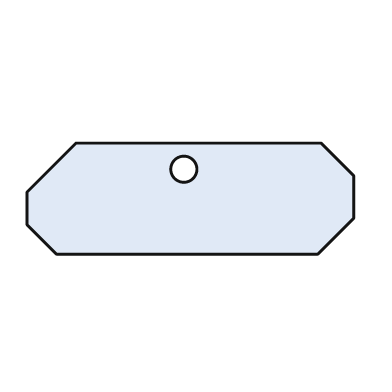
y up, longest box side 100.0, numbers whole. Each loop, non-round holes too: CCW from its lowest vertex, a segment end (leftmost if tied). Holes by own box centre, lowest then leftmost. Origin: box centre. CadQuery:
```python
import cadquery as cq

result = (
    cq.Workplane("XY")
    .moveTo(-41.0, -17.0)
    .lineTo(39.0, -17.0)
    .lineTo(50.0, -6.0)
    .lineTo(50.0, 7.0)
    .lineTo(40.0, 17.0)
    .lineTo(-35.0, 17.0)
    .lineTo(-50.0, 2.0)
    .lineTo(-50.0, -8.0)
    .close()
    .moveTo(-2.0, 9.0)
    .circle(4.0)
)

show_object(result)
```